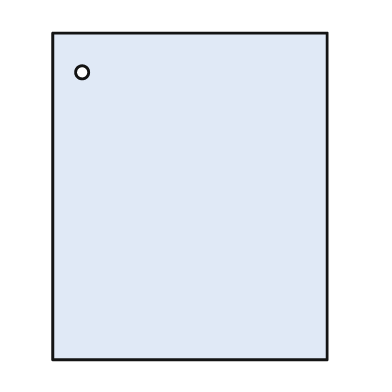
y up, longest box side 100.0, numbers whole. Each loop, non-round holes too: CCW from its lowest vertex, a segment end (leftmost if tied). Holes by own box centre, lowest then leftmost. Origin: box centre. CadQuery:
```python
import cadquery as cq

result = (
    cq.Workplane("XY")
    .moveTo(-42.0, -50.0)
    .lineTo(42.0, -50.0)
    .lineTo(42.0, 50.0)
    .lineTo(-42.0, 50.0)
    .close()
    .moveTo(-33.0, 38.0)
    .circle(2.0)
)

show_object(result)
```